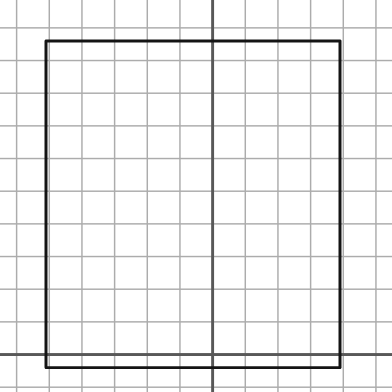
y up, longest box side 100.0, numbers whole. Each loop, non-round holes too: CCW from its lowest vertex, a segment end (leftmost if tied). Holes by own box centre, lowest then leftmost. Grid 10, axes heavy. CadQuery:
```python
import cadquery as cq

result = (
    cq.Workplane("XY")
    .moveTo(-51.0, -4.0)
    .lineTo(39.0, -4.0)
    .lineTo(39.0, 96.0)
    .lineTo(-51.0, 96.0)
    .close()
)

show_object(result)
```